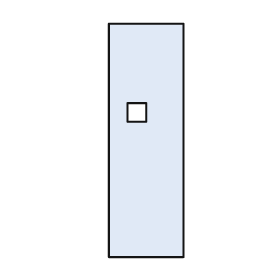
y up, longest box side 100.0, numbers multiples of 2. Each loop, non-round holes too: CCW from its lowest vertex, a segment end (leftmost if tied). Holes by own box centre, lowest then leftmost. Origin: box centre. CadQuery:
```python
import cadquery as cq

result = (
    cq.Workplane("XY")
    .moveTo(-16.0, -50.0)
    .lineTo(16.0, -50.0)
    .lineTo(16.0, 50.0)
    .lineTo(-16.0, 50.0)
    .close()
    .moveTo(-8.0, 8.0)
    .lineTo(0.0, 8.0)
    .lineTo(0.0, 16.0)
    .lineTo(-8.0, 16.0)
    .close()
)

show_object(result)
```